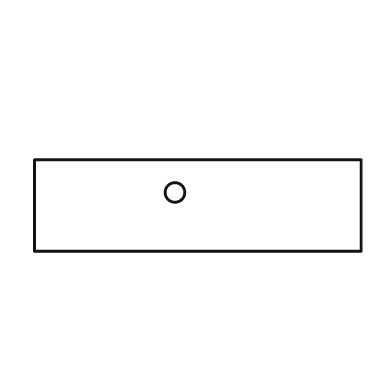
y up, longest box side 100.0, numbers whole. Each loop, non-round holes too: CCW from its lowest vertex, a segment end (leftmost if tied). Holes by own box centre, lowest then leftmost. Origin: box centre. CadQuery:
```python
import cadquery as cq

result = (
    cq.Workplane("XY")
    .moveTo(-50.0, -14.0)
    .lineTo(50.0, -14.0)
    .lineTo(50.0, 14.0)
    .lineTo(-50.0, 14.0)
    .close()
    .moveTo(-7.0, 4.0)
    .circle(3.0)
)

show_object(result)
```